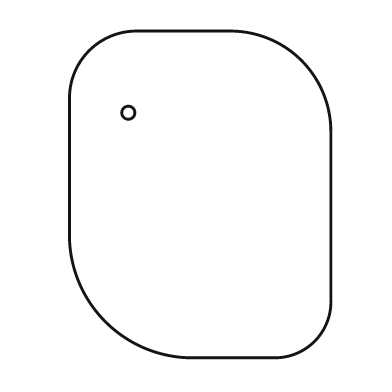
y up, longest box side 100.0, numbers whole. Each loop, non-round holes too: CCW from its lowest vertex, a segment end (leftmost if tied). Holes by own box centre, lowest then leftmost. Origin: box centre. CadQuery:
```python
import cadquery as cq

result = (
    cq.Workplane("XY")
    .moveTo(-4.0, -50.0)
    .lineTo(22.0, -50.0)
    .threePointArc((35.0, -45.0), (40.0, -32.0))
    .lineTo(40.0, 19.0)
    .threePointArc((31.0, 41.0), (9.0, 50.0))
    .lineTo(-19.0, 50.0)
    .threePointArc((-34.0, 44.0), (-40.0, 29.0))
    .lineTo(-40.0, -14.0)
    .threePointArc((-29.0, -39.0), (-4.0, -50.0))
    .close()
    .moveTo(-22.0, 25.0)
    .circle(2.0)
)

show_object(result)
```